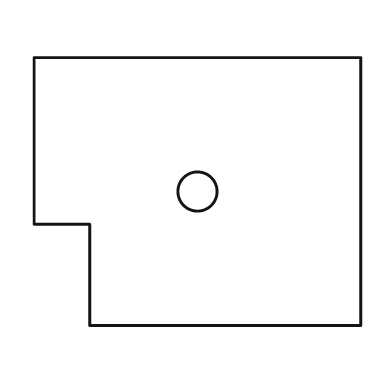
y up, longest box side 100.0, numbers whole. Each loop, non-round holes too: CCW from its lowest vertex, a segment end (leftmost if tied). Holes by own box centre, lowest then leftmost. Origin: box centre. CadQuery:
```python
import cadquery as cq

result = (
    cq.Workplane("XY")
    .moveTo(-33.0, -41.0)
    .lineTo(50.0, -41.0)
    .lineTo(50.0, 41.0)
    .lineTo(-50.0, 41.0)
    .lineTo(-50.0, -10.0)
    .lineTo(-33.0, -10.0)
    .close()
    .moveTo(0.0, 0.0)
    .circle(6.0)
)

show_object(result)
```